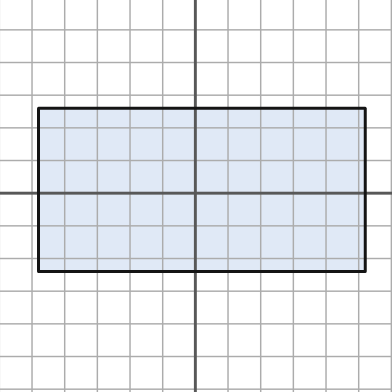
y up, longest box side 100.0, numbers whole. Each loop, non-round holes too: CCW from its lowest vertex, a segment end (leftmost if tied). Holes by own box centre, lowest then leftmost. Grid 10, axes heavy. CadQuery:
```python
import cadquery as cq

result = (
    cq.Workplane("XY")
    .moveTo(-48.0, -24.0)
    .lineTo(52.0, -24.0)
    .lineTo(52.0, 26.0)
    .lineTo(-48.0, 26.0)
    .close()
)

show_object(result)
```